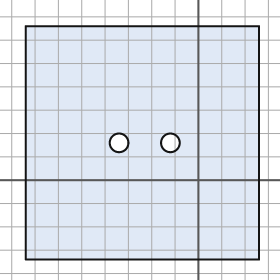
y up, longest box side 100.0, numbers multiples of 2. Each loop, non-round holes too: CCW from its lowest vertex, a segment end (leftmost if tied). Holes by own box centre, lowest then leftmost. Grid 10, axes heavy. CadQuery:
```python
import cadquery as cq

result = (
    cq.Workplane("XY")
    .moveTo(-74.0, -34.0)
    .lineTo(26.0, -34.0)
    .lineTo(26.0, 66.0)
    .lineTo(-74.0, 66.0)
    .close()
    .moveTo(-34.0, 16.0)
    .circle(4.0)
    .moveTo(-12.0, 16.0)
    .circle(4.0)
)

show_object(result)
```